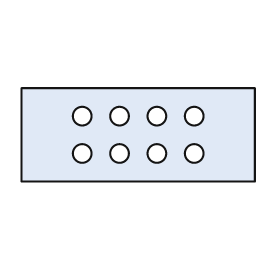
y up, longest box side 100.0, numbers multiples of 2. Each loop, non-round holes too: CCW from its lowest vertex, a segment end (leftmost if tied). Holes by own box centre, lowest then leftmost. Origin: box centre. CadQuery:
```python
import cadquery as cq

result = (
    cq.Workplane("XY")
    .moveTo(-50.0, -20.0)
    .lineTo(50.0, -20.0)
    .lineTo(50.0, 20.0)
    .lineTo(-50.0, 20.0)
    .close()
    .moveTo(-24.0, -8.0)
    .circle(4.0)
    .moveTo(-8.0, -8.0)
    .circle(4.0)
    .moveTo(8.0, -8.0)
    .circle(4.0)
    .moveTo(24.0, -8.0)
    .circle(4.0)
    .moveTo(-24.0, 8.0)
    .circle(4.0)
    .moveTo(-8.0, 8.0)
    .circle(4.0)
    .moveTo(8.0, 8.0)
    .circle(4.0)
    .moveTo(24.0, 8.0)
    .circle(4.0)
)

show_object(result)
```